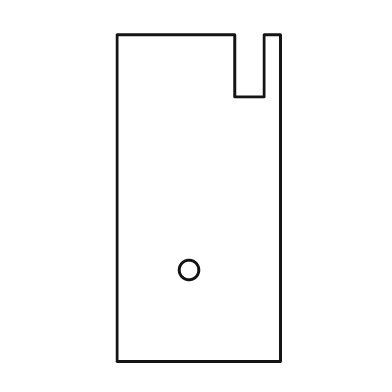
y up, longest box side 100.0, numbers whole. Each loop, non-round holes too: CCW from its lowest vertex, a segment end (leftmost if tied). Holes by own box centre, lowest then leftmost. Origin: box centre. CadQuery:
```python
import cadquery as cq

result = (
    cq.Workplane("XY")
    .moveTo(-25.0, -50.0)
    .lineTo(25.0, -50.0)
    .lineTo(25.0, 50.0)
    .lineTo(20.0, 50.0)
    .lineTo(20.0, 31.0)
    .lineTo(11.0, 31.0)
    .lineTo(11.0, 50.0)
    .lineTo(-25.0, 50.0)
    .close()
    .moveTo(-3.0, -22.0)
    .circle(3.0)
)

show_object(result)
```